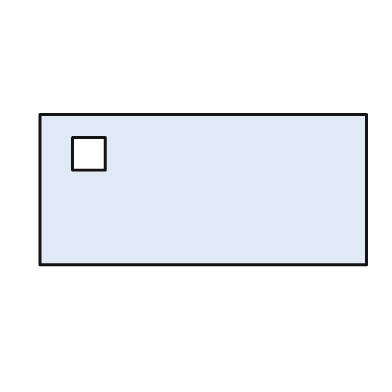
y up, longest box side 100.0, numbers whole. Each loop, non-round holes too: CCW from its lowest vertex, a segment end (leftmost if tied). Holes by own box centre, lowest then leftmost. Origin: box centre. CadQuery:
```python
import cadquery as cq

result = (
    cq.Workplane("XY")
    .moveTo(-50.0, -23.0)
    .lineTo(50.0, -23.0)
    .lineTo(50.0, 23.0)
    .lineTo(-50.0, 23.0)
    .close()
    .moveTo(-40.0, 6.0)
    .lineTo(-30.0, 6.0)
    .lineTo(-30.0, 16.0)
    .lineTo(-40.0, 16.0)
    .close()
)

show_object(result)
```